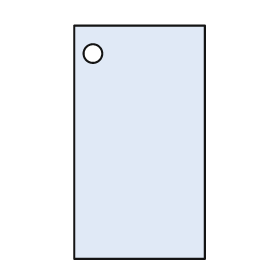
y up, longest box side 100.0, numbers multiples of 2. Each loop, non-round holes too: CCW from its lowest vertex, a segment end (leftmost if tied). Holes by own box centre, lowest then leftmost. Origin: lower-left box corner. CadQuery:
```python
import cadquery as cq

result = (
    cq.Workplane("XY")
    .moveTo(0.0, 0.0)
    .lineTo(56.0, 0.0)
    .lineTo(56.0, 100.0)
    .lineTo(0.0, 100.0)
    .close()
    .moveTo(8.0, 88.0)
    .circle(4.0)
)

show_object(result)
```